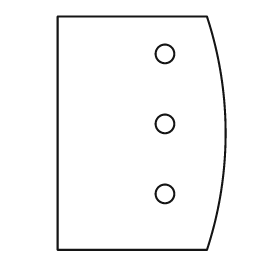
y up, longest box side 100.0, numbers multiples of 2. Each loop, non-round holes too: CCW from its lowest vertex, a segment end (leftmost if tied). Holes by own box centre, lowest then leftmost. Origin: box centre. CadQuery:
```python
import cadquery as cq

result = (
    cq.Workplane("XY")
    .moveTo(-36.0, -50.0)
    .lineTo(28.0, -50.0)
    .threePointArc((36.0, 0.0), (28.0, 50.0))
    .lineTo(-36.0, 50.0)
    .close()
    .moveTo(10.0, -26.0)
    .circle(4.0)
    .moveTo(10.0, 4.0)
    .circle(4.0)
    .moveTo(10.0, 34.0)
    .circle(4.0)
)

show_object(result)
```